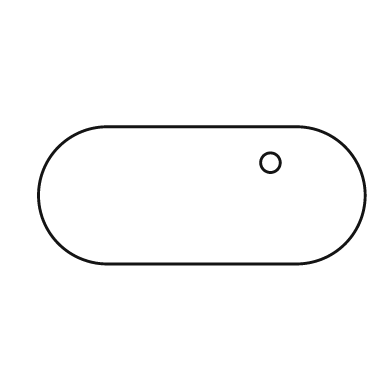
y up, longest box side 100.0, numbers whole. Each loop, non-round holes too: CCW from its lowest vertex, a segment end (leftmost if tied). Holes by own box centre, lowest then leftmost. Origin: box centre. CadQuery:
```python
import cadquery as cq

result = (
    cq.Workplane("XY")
    .moveTo(-29.0, -21.0)
    .lineTo(29.0, -21.0)
    .threePointArc((50.0, 0.0), (29.0, 21.0))
    .lineTo(-29.0, 21.0)
    .threePointArc((-50.0, 0.0), (-29.0, -21.0))
    .close()
    .moveTo(21.0, 10.0)
    .circle(3.0)
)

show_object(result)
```